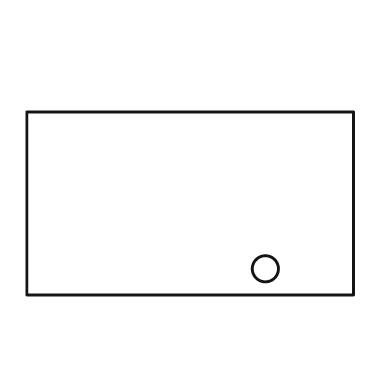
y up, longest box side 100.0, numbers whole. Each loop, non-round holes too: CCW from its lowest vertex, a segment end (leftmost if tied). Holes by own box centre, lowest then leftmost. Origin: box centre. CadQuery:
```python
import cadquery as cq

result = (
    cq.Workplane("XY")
    .moveTo(-50.0, -28.0)
    .lineTo(50.0, -28.0)
    .lineTo(50.0, 28.0)
    .lineTo(-50.0, 28.0)
    .close()
    .moveTo(23.0, -20.0)
    .circle(4.0)
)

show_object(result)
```